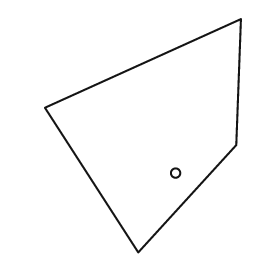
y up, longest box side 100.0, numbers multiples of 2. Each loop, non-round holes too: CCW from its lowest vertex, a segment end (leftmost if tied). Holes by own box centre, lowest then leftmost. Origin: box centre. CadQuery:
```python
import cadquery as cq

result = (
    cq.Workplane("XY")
    .moveTo(-2.0, -50.0)
    .lineTo(40.0, -4.0)
    .lineTo(42.0, 50.0)
    .lineTo(-42.0, 12.0)
    .close()
    .moveTo(14.0, -16.0)
    .circle(2.0)
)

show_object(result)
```